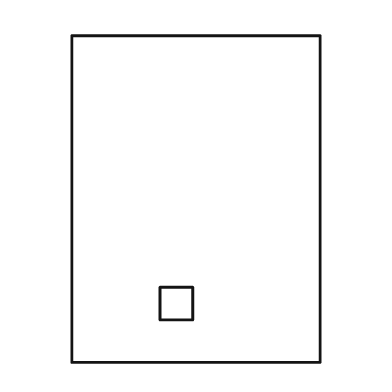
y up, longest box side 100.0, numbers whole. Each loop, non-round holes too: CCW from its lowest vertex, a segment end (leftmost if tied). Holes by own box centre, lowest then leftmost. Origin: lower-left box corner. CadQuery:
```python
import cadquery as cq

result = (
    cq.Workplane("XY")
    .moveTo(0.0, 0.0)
    .lineTo(76.0, 0.0)
    .lineTo(76.0, 100.0)
    .lineTo(0.0, 100.0)
    .close()
    .moveTo(27.0, 13.0)
    .lineTo(37.0, 13.0)
    .lineTo(37.0, 23.0)
    .lineTo(27.0, 23.0)
    .close()
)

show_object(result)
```